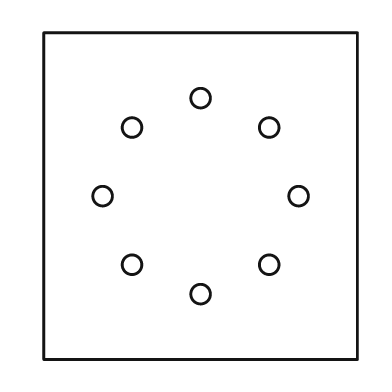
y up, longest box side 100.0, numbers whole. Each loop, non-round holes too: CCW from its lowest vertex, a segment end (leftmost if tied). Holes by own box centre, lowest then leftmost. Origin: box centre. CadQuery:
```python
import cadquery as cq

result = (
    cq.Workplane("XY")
    .moveTo(-48.0, -50.0)
    .lineTo(48.0, -50.0)
    .lineTo(48.0, 50.0)
    .lineTo(-48.0, 50.0)
    .close()
    .moveTo(0.0, -30.0)
    .circle(3.0)
    .moveTo(-21.0, -21.0)
    .circle(3.0)
    .moveTo(21.0, -21.0)
    .circle(3.0)
    .moveTo(-30.0, 0.0)
    .circle(3.0)
    .moveTo(30.0, 0.0)
    .circle(3.0)
    .moveTo(-21.0, 21.0)
    .circle(3.0)
    .moveTo(21.0, 21.0)
    .circle(3.0)
    .moveTo(0.0, 30.0)
    .circle(3.0)
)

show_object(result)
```